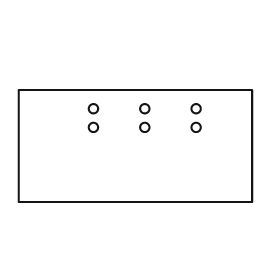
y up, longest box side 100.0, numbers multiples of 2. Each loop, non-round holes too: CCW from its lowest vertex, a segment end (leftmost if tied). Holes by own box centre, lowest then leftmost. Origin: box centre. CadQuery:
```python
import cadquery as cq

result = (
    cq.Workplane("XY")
    .moveTo(-50.0, -24.0)
    .lineTo(50.0, -24.0)
    .lineTo(50.0, 24.0)
    .lineTo(-50.0, 24.0)
    .close()
    .moveTo(-18.0, 8.0)
    .circle(2.0)
    .moveTo(4.0, 8.0)
    .circle(2.0)
    .moveTo(26.0, 8.0)
    .circle(2.0)
    .moveTo(-18.0, 16.0)
    .circle(2.0)
    .moveTo(4.0, 16.0)
    .circle(2.0)
    .moveTo(26.0, 16.0)
    .circle(2.0)
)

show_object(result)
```